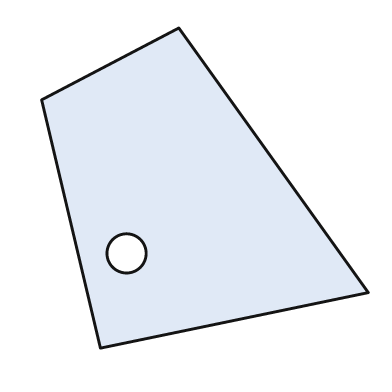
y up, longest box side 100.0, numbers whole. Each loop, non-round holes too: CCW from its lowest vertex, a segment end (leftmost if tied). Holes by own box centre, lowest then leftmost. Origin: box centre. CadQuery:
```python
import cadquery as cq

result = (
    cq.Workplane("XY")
    .moveTo(-32.0, -49.0)
    .lineTo(50.0, -32.0)
    .lineTo(-8.0, 49.0)
    .lineTo(-50.0, 27.0)
    .close()
    .moveTo(-24.0, -20.0)
    .circle(6.0)
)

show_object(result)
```